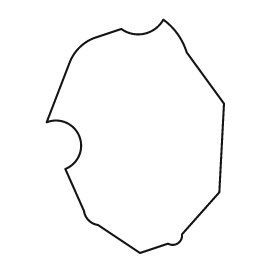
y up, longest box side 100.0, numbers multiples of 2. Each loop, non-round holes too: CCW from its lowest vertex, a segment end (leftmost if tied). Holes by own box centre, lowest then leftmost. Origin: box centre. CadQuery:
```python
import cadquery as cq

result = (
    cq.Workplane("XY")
    .moveTo(2.0, -50.0)
    .lineTo(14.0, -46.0)
    .threePointArc((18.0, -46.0), (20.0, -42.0))
    .lineTo(36.0, -24.0)
    .lineTo(38.0, 14.0)
    .lineTo(22.0, 36.0)
    .threePointArc((18.0, 44.0), (12.0, 50.0))
    .threePointArc((4.0, 44.0), (-6.0, 46.0))
    .lineTo(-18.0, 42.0)
    .threePointArc((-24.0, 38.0), (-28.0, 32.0))
    .lineTo(-38.0, 6.0)
    .threePointArc((-24.0, 0.0), (-30.0, -14.0))
    .lineTo(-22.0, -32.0)
    .threePointArc((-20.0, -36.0), (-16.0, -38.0))
    .close()
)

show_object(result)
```